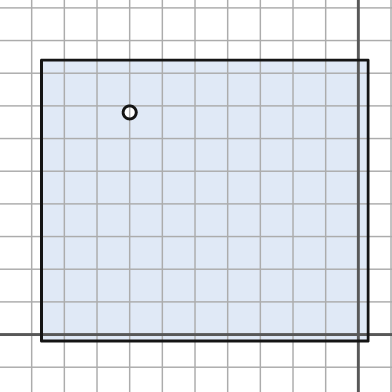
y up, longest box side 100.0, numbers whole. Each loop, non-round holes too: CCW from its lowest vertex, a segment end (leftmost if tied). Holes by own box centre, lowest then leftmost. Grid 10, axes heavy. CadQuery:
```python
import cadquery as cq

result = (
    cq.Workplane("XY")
    .moveTo(-97.0, -2.0)
    .lineTo(3.0, -2.0)
    .lineTo(3.0, 84.0)
    .lineTo(-97.0, 84.0)
    .close()
    .moveTo(-70.0, 68.0)
    .circle(2.0)
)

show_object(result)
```